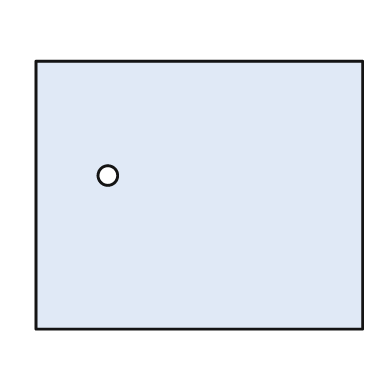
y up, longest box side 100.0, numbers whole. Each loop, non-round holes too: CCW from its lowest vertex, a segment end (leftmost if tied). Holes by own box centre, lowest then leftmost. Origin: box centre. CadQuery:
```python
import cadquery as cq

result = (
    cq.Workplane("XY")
    .moveTo(-50.0, -41.0)
    .lineTo(50.0, -41.0)
    .lineTo(50.0, 41.0)
    .lineTo(-50.0, 41.0)
    .close()
    .moveTo(-28.0, 6.0)
    .circle(3.0)
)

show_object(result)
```